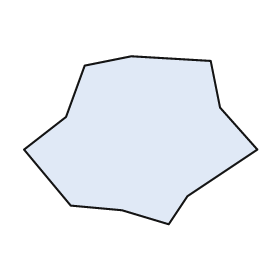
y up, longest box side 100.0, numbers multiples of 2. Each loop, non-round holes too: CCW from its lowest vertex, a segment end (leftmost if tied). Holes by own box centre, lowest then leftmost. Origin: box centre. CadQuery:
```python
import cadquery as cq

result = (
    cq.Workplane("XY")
    .moveTo(12.0, -36.0)
    .lineTo(20.0, -24.0)
    .lineTo(50.0, -4.0)
    .lineTo(34.0, 14.0)
    .lineTo(30.0, 34.0)
    .lineTo(-4.0, 36.0)
    .lineTo(-24.0, 32.0)
    .lineTo(-32.0, 10.0)
    .lineTo(-50.0, -4.0)
    .lineTo(-30.0, -28.0)
    .lineTo(-8.0, -30.0)
    .close()
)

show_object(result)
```